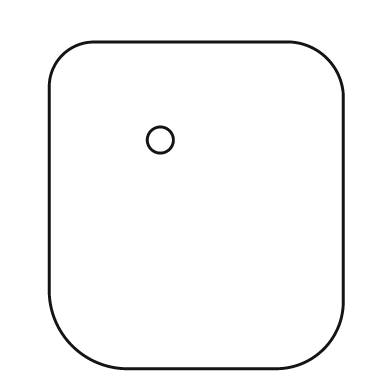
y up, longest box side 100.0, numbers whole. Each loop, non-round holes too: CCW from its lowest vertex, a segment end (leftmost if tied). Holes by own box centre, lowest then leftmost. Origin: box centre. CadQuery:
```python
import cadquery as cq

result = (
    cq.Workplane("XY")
    .moveTo(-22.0, -50.0)
    .lineTo(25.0, -50.0)
    .threePointArc((39.0, -44.0), (45.0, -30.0))
    .lineTo(45.0, 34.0)
    .threePointArc((40.0, 45.0), (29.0, 50.0))
    .lineTo(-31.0, 50.0)
    .threePointArc((-41.0, 46.0), (-45.0, 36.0))
    .lineTo(-45.0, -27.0)
    .threePointArc((-38.0, -43.0), (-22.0, -50.0))
    .close()
    .moveTo(-11.0, 20.0)
    .circle(4.0)
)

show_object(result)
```